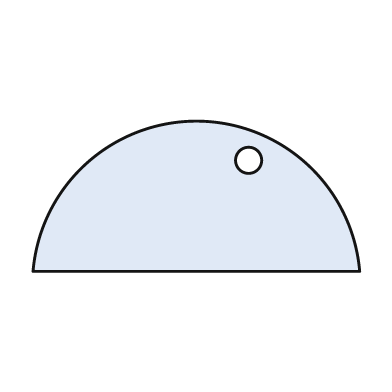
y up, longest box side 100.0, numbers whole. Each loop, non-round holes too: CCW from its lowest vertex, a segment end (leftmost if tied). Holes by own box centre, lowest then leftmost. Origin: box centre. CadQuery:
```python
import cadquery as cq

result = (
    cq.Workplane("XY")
    .moveTo(-50.0, -23.0)
    .lineTo(50.0, -23.0)
    .threePointArc((0.0, 23.0), (-50.0, -23.0))
    .close()
    .moveTo(16.0, 11.0)
    .circle(4.0)
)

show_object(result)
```